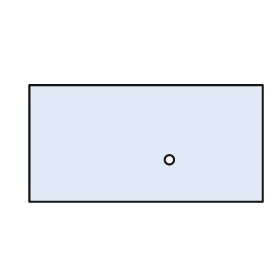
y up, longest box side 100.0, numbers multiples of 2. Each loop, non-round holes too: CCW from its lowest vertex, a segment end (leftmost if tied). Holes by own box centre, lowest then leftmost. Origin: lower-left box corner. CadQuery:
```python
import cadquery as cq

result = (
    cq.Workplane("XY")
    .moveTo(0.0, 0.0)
    .lineTo(100.0, 0.0)
    .lineTo(100.0, 50.0)
    .lineTo(0.0, 50.0)
    .close()
    .moveTo(60.0, 18.0)
    .circle(2.0)
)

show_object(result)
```